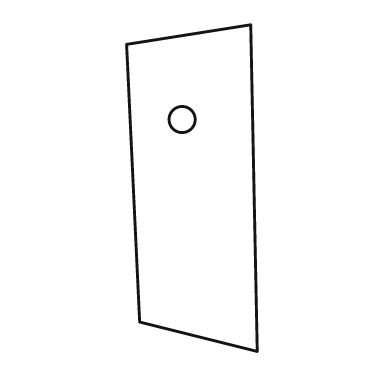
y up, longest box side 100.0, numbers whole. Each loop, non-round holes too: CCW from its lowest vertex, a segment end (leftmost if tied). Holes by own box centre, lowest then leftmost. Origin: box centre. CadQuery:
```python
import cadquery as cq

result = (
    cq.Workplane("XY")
    .moveTo(20.0, -50.0)
    .lineTo(18.0, 50.0)
    .lineTo(-20.0, 44.0)
    .lineTo(-16.0, -41.0)
    .close()
    .moveTo(-3.0, 21.0)
    .circle(4.0)
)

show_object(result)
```